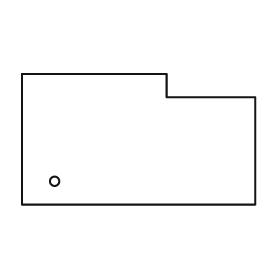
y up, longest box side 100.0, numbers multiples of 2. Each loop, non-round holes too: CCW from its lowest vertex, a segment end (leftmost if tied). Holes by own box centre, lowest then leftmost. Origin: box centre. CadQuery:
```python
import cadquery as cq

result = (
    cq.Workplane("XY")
    .moveTo(-50.0, -28.0)
    .lineTo(50.0, -28.0)
    .lineTo(50.0, 18.0)
    .lineTo(12.0, 18.0)
    .lineTo(12.0, 28.0)
    .lineTo(-50.0, 28.0)
    .close()
    .moveTo(-36.0, -18.0)
    .circle(2.0)
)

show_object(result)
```